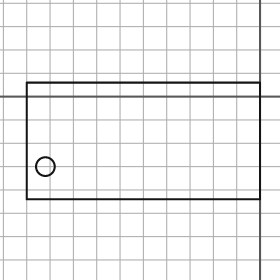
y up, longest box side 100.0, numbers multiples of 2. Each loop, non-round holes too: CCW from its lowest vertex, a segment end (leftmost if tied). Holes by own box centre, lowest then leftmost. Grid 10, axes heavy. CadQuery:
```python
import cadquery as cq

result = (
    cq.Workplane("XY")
    .moveTo(-100.0, -44.0)
    .lineTo(0.0, -44.0)
    .lineTo(0.0, 6.0)
    .lineTo(-100.0, 6.0)
    .close()
    .moveTo(-92.0, -30.0)
    .circle(4.0)
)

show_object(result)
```